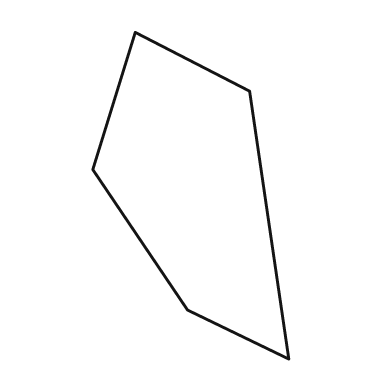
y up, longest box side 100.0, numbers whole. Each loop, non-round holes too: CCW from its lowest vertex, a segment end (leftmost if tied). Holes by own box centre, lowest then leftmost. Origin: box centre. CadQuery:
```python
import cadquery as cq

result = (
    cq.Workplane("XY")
    .moveTo(30.0, -50.0)
    .lineTo(18.0, 32.0)
    .lineTo(-17.0, 50.0)
    .lineTo(-30.0, 8.0)
    .lineTo(-1.0, -35.0)
    .close()
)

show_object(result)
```